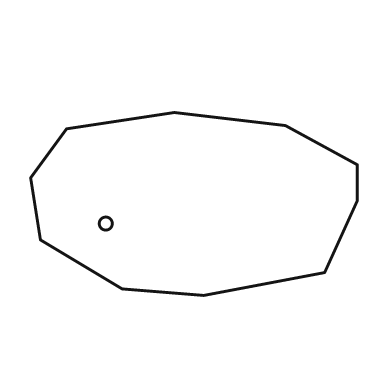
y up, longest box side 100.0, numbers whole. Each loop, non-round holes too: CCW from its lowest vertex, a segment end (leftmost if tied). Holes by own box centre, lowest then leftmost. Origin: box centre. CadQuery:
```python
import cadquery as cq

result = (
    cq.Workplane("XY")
    .moveTo(3.0, -28.0)
    .lineTo(40.0, -21.0)
    .lineTo(50.0, 1.0)
    .lineTo(50.0, 12.0)
    .lineTo(28.0, 24.0)
    .lineTo(-6.0, 28.0)
    .lineTo(-39.0, 23.0)
    .lineTo(-50.0, 8.0)
    .lineTo(-47.0, -11.0)
    .lineTo(-22.0, -26.0)
    .close()
    .moveTo(-27.0, -6.0)
    .circle(2.0)
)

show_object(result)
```